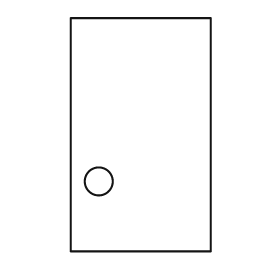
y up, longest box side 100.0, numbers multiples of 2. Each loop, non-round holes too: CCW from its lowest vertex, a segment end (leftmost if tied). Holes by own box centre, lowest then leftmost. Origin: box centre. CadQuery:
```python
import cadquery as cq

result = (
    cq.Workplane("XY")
    .moveTo(-30.0, -50.0)
    .lineTo(30.0, -50.0)
    .lineTo(30.0, 50.0)
    .lineTo(-30.0, 50.0)
    .close()
    .moveTo(-18.0, -20.0)
    .circle(6.0)
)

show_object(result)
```